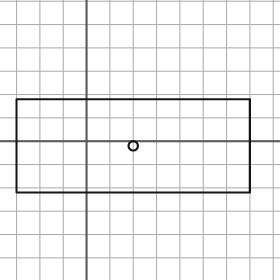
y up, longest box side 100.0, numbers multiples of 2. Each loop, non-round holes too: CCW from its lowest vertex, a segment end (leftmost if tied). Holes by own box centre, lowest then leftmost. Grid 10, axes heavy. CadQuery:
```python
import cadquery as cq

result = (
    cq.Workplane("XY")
    .moveTo(-30.0, -22.0)
    .lineTo(70.0, -22.0)
    .lineTo(70.0, 18.0)
    .lineTo(-30.0, 18.0)
    .close()
    .moveTo(20.0, -2.0)
    .circle(2.0)
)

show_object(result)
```